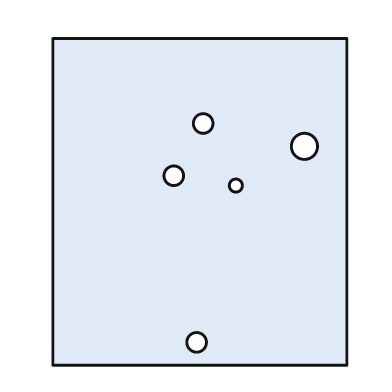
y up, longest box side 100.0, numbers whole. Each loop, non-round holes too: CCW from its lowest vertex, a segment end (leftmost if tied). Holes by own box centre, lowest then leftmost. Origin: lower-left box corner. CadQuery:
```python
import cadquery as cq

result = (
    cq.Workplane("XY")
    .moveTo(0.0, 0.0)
    .lineTo(90.0, 0.0)
    .lineTo(90.0, 100.0)
    .lineTo(0.0, 100.0)
    .close()
    .moveTo(44.0, 7.0)
    .circle(3.0)
    .moveTo(56.0, 55.0)
    .circle(2.0)
    .moveTo(37.0, 58.0)
    .circle(3.0)
    .moveTo(77.0, 67.0)
    .circle(4.0)
    .moveTo(46.0, 74.0)
    .circle(3.0)
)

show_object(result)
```